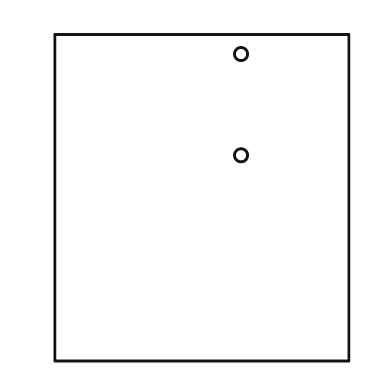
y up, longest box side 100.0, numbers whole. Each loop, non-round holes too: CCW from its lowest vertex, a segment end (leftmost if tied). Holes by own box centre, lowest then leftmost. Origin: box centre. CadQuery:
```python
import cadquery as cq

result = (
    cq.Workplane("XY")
    .moveTo(-45.0, -50.0)
    .lineTo(45.0, -50.0)
    .lineTo(45.0, 50.0)
    .lineTo(-45.0, 50.0)
    .close()
    .moveTo(12.0, 13.0)
    .circle(2.0)
    .moveTo(12.0, 44.0)
    .circle(2.0)
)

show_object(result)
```